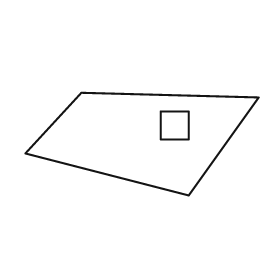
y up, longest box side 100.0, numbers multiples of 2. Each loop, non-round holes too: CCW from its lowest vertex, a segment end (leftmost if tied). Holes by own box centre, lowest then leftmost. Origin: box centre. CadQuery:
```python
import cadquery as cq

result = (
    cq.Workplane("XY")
    .moveTo(20.0, -22.0)
    .lineTo(50.0, 20.0)
    .lineTo(-26.0, 22.0)
    .lineTo(-50.0, -4.0)
    .close()
    .moveTo(8.0, 2.0)
    .lineTo(20.0, 2.0)
    .lineTo(20.0, 14.0)
    .lineTo(8.0, 14.0)
    .close()
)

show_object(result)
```